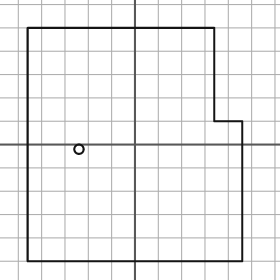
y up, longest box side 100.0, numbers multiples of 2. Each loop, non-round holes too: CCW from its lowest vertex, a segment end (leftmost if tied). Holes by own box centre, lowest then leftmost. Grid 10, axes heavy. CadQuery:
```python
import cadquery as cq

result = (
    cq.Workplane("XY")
    .moveTo(-46.0, -50.0)
    .lineTo(46.0, -50.0)
    .lineTo(46.0, 10.0)
    .lineTo(34.0, 10.0)
    .lineTo(34.0, 50.0)
    .lineTo(-46.0, 50.0)
    .close()
    .moveTo(-24.0, -2.0)
    .circle(2.0)
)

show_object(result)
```